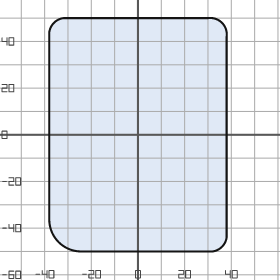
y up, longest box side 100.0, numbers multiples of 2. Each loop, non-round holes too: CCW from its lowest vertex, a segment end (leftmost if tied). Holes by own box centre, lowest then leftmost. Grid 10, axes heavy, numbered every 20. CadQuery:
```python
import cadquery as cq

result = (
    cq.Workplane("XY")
    .moveTo(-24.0, -50.0)
    .lineTo(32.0, -50.0)
    .threePointArc((36.0, -48.0), (38.0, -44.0))
    .lineTo(38.0, 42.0)
    .threePointArc((36.0, 48.0), (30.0, 50.0))
    .lineTo(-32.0, 50.0)
    .threePointArc((-36.0, 48.0), (-38.0, 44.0))
    .lineTo(-38.0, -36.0)
    .threePointArc((-34.0, -46.0), (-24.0, -50.0))
    .close()
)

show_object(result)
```